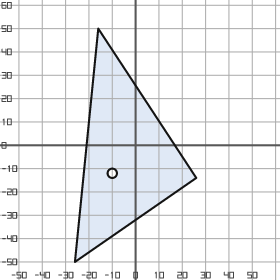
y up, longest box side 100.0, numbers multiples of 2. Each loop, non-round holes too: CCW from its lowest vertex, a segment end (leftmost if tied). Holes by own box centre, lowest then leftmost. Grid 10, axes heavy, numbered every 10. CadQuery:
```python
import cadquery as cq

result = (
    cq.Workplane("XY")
    .moveTo(-26.0, -50.0)
    .lineTo(26.0, -14.0)
    .lineTo(-16.0, 50.0)
    .close()
    .moveTo(-10.0, -12.0)
    .circle(2.0)
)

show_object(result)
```